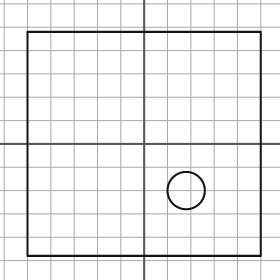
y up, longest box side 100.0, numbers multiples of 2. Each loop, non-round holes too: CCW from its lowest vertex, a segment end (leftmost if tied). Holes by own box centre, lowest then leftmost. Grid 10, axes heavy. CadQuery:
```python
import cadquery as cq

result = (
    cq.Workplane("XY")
    .moveTo(-50.0, -48.0)
    .lineTo(50.0, -48.0)
    .lineTo(50.0, 48.0)
    .lineTo(-50.0, 48.0)
    .close()
    .moveTo(18.0, -20.0)
    .circle(8.0)
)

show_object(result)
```